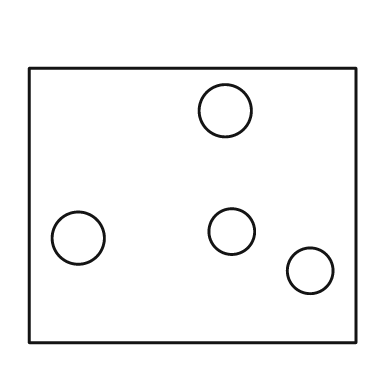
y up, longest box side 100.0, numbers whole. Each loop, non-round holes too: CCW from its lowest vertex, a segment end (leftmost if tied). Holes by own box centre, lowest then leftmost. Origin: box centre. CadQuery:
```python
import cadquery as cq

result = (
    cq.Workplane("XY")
    .moveTo(-50.0, -42.0)
    .lineTo(50.0, -42.0)
    .lineTo(50.0, 42.0)
    .lineTo(-50.0, 42.0)
    .close()
    .moveTo(36.0, -20.0)
    .circle(7.0)
    .moveTo(-35.0, -10.0)
    .circle(8.0)
    .moveTo(12.0, -8.0)
    .circle(7.0)
    .moveTo(10.0, 29.0)
    .circle(8.0)
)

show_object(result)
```